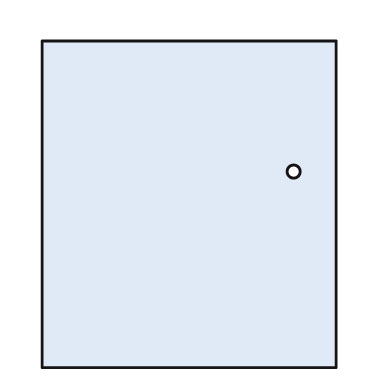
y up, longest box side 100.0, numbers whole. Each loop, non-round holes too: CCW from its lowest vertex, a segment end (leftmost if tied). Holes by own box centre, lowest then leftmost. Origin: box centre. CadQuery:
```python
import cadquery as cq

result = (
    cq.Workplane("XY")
    .moveTo(-45.0, -50.0)
    .lineTo(45.0, -50.0)
    .lineTo(45.0, 50.0)
    .lineTo(-45.0, 50.0)
    .close()
    .moveTo(32.0, 10.0)
    .circle(2.0)
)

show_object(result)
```